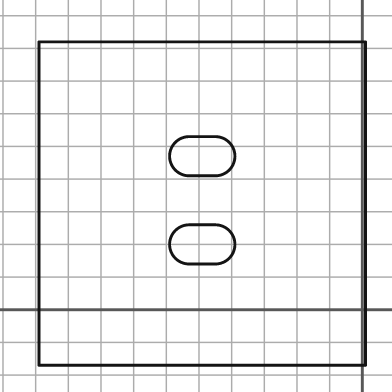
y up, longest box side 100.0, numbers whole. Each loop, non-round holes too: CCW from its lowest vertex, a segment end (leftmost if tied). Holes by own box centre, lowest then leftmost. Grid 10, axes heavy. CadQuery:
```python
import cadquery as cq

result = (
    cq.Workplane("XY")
    .moveTo(-99.0, -17.0)
    .lineTo(1.0, -17.0)
    .lineTo(1.0, 82.0)
    .lineTo(-99.0, 82.0)
    .close()
    .moveTo(-53.0, 14.0)
    .lineTo(-45.0, 14.0)
    .threePointArc((-39.0, 20.0), (-45.0, 26.0))
    .lineTo(-53.0, 26.0)
    .threePointArc((-59.0, 20.0), (-53.0, 14.0))
    .close()
    .moveTo(-53.0, 41.0)
    .lineTo(-45.0, 41.0)
    .threePointArc((-39.0, 47.0), (-45.0, 53.0))
    .lineTo(-53.0, 53.0)
    .threePointArc((-59.0, 47.0), (-53.0, 41.0))
    .close()
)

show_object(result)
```